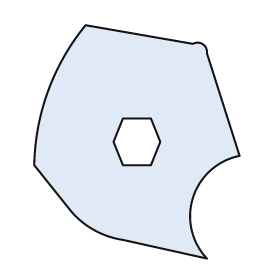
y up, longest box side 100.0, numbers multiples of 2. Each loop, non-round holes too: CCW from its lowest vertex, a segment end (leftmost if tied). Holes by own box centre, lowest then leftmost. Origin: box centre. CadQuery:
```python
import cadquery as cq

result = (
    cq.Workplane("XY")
    .moveTo(30.0, -50.0)
    .threePointArc((24.0, -24.0), (44.0, -6.0))
    .lineTo(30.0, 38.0)
    .threePointArc((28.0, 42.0), (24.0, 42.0))
    .lineTo(-22.0, 50.0)
    .threePointArc((-38.0, 22.0), (-44.0, -10.0))
    .lineTo(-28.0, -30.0)
    .threePointArc((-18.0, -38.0), (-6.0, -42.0))
    .close()
    .moveTo(-6.0, -10.0)
    .lineTo(6.0, -10.0)
    .lineTo(10.0, 0.0)
    .lineTo(6.0, 10.0)
    .lineTo(-6.0, 10.0)
    .lineTo(-10.0, 0.0)
    .close()
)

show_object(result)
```